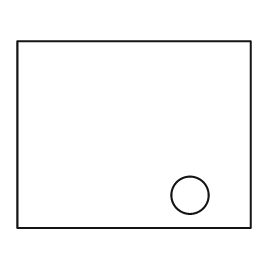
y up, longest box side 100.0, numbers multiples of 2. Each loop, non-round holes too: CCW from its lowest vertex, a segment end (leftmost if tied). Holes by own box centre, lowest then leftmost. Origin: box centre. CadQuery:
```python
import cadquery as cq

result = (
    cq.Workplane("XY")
    .moveTo(-50.0, -40.0)
    .lineTo(50.0, -40.0)
    .lineTo(50.0, 40.0)
    .lineTo(-50.0, 40.0)
    .close()
    .moveTo(24.0, -26.0)
    .circle(8.0)
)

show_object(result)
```